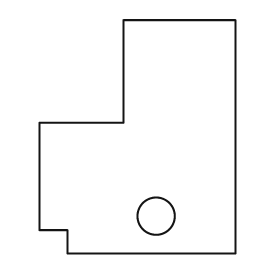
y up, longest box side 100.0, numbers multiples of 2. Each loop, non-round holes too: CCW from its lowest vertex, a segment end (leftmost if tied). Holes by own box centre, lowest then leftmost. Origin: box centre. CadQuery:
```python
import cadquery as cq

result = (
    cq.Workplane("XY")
    .moveTo(-30.0, -50.0)
    .lineTo(42.0, -50.0)
    .lineTo(42.0, 50.0)
    .lineTo(-6.0, 50.0)
    .lineTo(-6.0, 6.0)
    .lineTo(-42.0, 6.0)
    .lineTo(-42.0, -40.0)
    .lineTo(-30.0, -40.0)
    .close()
    .moveTo(8.0, -34.0)
    .circle(8.0)
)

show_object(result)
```